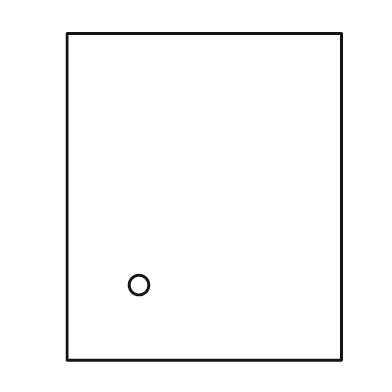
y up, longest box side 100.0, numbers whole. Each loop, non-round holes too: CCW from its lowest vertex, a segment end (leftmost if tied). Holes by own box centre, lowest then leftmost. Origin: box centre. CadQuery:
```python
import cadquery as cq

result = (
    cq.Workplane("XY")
    .moveTo(-42.0, -50.0)
    .lineTo(42.0, -50.0)
    .lineTo(42.0, 50.0)
    .lineTo(-42.0, 50.0)
    .close()
    .moveTo(-20.0, -27.0)
    .circle(3.0)
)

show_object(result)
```